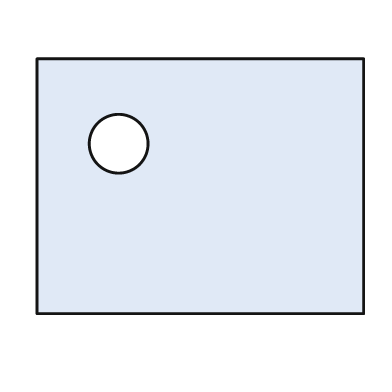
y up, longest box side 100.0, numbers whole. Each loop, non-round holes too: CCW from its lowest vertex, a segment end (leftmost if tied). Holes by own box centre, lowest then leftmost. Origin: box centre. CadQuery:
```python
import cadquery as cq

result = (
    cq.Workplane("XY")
    .moveTo(-50.0, -39.0)
    .lineTo(50.0, -39.0)
    .lineTo(50.0, 39.0)
    .lineTo(-50.0, 39.0)
    .close()
    .moveTo(-25.0, 13.0)
    .circle(9.0)
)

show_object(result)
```